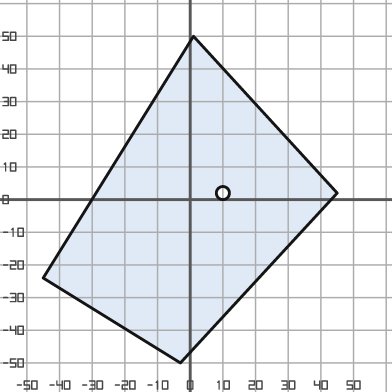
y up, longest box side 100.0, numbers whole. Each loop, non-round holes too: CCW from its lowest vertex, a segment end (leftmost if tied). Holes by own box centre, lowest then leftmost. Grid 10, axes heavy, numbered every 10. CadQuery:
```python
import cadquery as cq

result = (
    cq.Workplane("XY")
    .moveTo(-3.0, -50.0)
    .lineTo(45.0, 2.0)
    .lineTo(1.0, 50.0)
    .lineTo(-45.0, -24.0)
    .close()
    .moveTo(10.0, 2.0)
    .circle(2.0)
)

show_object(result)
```